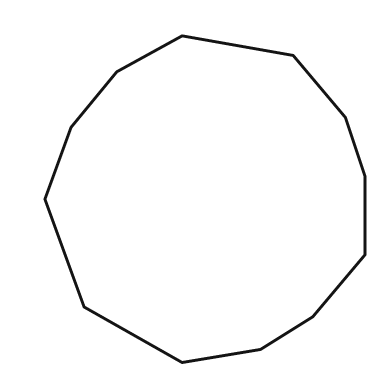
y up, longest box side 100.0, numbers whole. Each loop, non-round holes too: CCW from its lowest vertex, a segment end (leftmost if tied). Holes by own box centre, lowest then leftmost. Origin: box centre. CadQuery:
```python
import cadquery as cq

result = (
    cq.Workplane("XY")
    .moveTo(-7.0, -50.0)
    .lineTo(17.0, -46.0)
    .lineTo(33.0, -36.0)
    .lineTo(49.0, -17.0)
    .lineTo(49.0, 7.0)
    .lineTo(43.0, 25.0)
    .lineTo(27.0, 44.0)
    .lineTo(-7.0, 50.0)
    .lineTo(-27.0, 39.0)
    .lineTo(-41.0, 22.0)
    .lineTo(-49.0, 0.0)
    .lineTo(-37.0, -33.0)
    .close()
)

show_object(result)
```